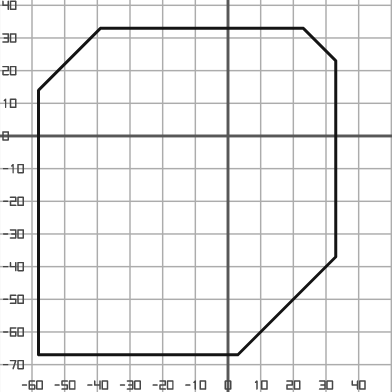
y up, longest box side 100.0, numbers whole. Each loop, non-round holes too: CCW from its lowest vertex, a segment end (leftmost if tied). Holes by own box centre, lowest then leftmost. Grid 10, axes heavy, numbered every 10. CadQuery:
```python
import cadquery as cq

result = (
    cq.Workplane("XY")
    .moveTo(-58.0, -67.0)
    .lineTo(3.0, -67.0)
    .lineTo(33.0, -37.0)
    .lineTo(33.0, 23.0)
    .lineTo(23.0, 33.0)
    .lineTo(-39.0, 33.0)
    .lineTo(-58.0, 14.0)
    .close()
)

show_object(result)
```